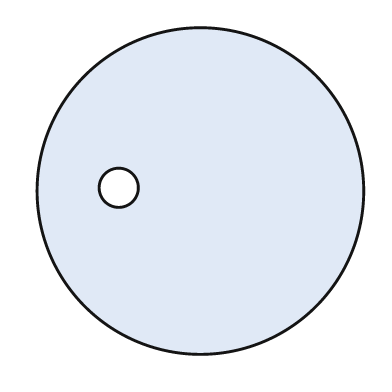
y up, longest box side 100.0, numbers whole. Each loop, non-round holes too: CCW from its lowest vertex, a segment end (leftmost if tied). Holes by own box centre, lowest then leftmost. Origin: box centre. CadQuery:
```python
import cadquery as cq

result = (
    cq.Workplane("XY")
    .moveTo(0.0, 0.0)
    .circle(50.0)
    .moveTo(-25.0, 1.0)
    .circle(6.0)
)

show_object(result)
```